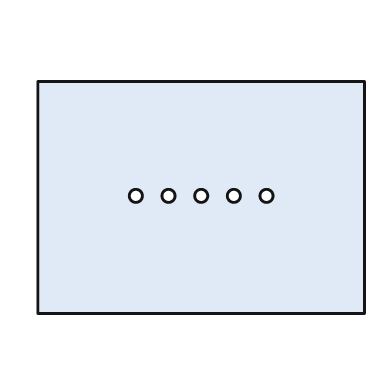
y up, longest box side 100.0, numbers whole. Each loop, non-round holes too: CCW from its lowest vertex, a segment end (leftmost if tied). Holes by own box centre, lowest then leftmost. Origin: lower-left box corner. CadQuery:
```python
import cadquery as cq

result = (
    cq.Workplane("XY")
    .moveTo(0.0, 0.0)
    .lineTo(100.0, 0.0)
    .lineTo(100.0, 71.0)
    .lineTo(0.0, 71.0)
    .close()
    .moveTo(30.0, 36.0)
    .circle(2.0)
    .moveTo(40.0, 36.0)
    .circle(2.0)
    .moveTo(50.0, 36.0)
    .circle(2.0)
    .moveTo(60.0, 36.0)
    .circle(2.0)
    .moveTo(70.0, 36.0)
    .circle(2.0)
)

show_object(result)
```